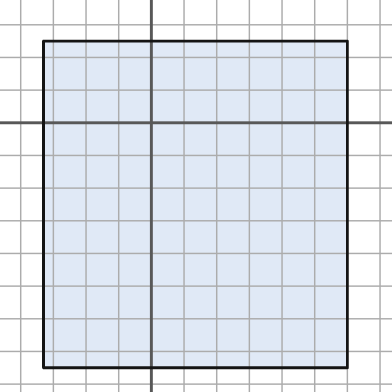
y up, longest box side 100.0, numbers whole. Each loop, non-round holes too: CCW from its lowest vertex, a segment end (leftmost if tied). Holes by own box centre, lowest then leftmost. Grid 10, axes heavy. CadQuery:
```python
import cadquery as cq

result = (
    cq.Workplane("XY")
    .moveTo(-33.0, -75.0)
    .lineTo(60.0, -75.0)
    .lineTo(60.0, 25.0)
    .lineTo(-33.0, 25.0)
    .close()
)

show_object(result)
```